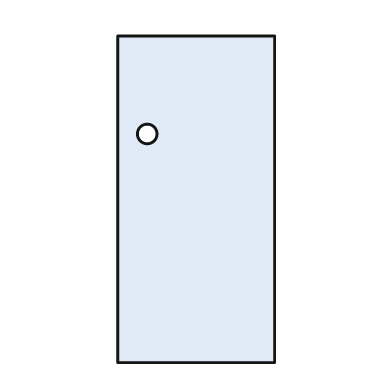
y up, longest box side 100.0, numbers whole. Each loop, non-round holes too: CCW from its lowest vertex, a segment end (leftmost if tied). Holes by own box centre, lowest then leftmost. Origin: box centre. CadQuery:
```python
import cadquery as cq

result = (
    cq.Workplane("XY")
    .moveTo(-24.0, -50.0)
    .lineTo(24.0, -50.0)
    .lineTo(24.0, 50.0)
    .lineTo(-24.0, 50.0)
    .close()
    .moveTo(-15.0, 20.0)
    .circle(3.0)
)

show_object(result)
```